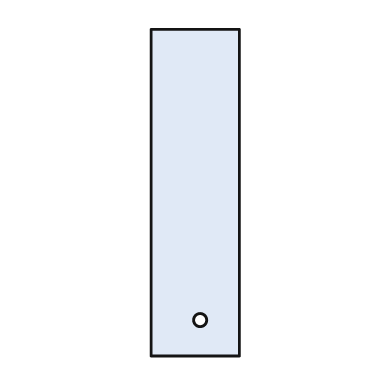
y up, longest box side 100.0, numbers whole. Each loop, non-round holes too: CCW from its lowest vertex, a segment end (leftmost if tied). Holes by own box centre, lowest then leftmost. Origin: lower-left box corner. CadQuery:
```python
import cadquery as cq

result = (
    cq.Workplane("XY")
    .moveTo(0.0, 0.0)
    .lineTo(27.0, 0.0)
    .lineTo(27.0, 100.0)
    .lineTo(0.0, 100.0)
    .close()
    .moveTo(15.0, 11.0)
    .circle(2.0)
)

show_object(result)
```